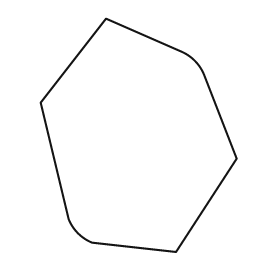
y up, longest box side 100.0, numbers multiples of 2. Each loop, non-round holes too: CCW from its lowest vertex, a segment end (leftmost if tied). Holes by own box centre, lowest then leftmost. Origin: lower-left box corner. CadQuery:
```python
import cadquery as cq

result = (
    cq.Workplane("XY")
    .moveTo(58.0, 0.0)
    .lineTo(84.0, 40.0)
    .lineTo(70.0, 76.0)
    .threePointArc((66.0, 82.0), (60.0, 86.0))
    .lineTo(28.0, 100.0)
    .lineTo(0.0, 64.0)
    .lineTo(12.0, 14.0)
    .threePointArc((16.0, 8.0), (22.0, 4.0))
    .close()
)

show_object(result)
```